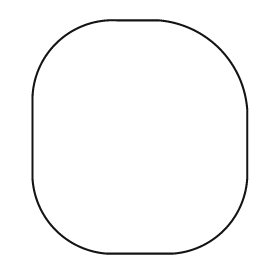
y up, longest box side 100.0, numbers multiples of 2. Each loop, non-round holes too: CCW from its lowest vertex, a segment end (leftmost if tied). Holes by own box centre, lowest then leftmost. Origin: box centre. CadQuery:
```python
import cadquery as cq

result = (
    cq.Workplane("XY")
    .moveTo(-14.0, -50.0)
    .lineTo(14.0, -50.0)
    .threePointArc((36.0, -40.0), (46.0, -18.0))
    .lineTo(46.0, 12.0)
    .threePointArc((34.0, 38.0), (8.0, 50.0))
    .lineTo(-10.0, 50.0)
    .threePointArc((-36.0, 40.0), (-46.0, 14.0))
    .lineTo(-46.0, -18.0)
    .threePointArc((-36.0, -40.0), (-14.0, -50.0))
    .close()
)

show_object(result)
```